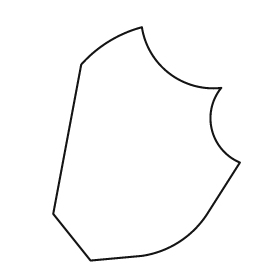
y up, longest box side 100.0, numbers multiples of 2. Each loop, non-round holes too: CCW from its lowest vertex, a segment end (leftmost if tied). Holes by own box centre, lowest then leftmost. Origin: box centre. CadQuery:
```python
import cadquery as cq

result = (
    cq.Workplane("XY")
    .moveTo(-24.0, -50.0)
    .lineTo(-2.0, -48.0)
    .threePointArc((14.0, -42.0), (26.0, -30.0))
    .lineTo(40.0, -8.0)
    .threePointArc((28.0, 6.0), (32.0, 24.0))
    .threePointArc((10.0, 30.0), (-2.0, 50.0))
    .threePointArc((-16.0, 44.0), (-28.0, 34.0))
    .lineTo(-40.0, -30.0)
    .close()
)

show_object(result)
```